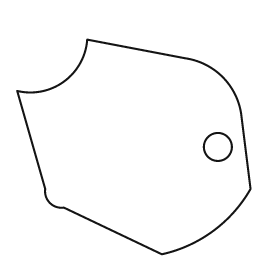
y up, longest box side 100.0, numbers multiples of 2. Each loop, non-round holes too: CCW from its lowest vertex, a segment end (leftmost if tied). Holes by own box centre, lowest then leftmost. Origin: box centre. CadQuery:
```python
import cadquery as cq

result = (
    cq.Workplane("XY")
    .moveTo(12.0, -46.0)
    .threePointArc((34.0, -36.0), (50.0, -18.0))
    .lineTo(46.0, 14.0)
    .threePointArc((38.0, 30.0), (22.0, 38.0))
    .lineTo(-20.0, 46.0)
    .threePointArc((-30.0, 28.0), (-50.0, 24.0))
    .lineTo(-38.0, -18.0)
    .threePointArc((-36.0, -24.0), (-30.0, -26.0))
    .close()
    .moveTo(36.0, 0.0)
    .circle(6.0)
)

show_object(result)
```